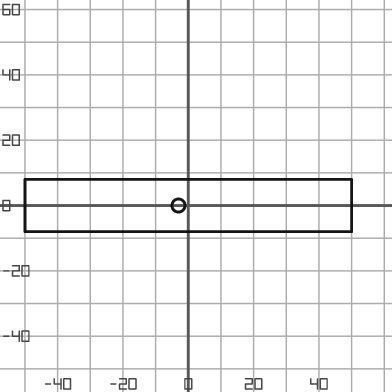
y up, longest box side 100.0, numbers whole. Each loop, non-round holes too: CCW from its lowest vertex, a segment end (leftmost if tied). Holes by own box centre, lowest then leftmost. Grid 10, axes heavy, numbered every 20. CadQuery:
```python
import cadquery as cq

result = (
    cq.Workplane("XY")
    .moveTo(-50.0, -8.0)
    .lineTo(50.0, -8.0)
    .lineTo(50.0, 8.0)
    .lineTo(-50.0, 8.0)
    .close()
    .moveTo(-3.0, 0.0)
    .circle(2.0)
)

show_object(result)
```